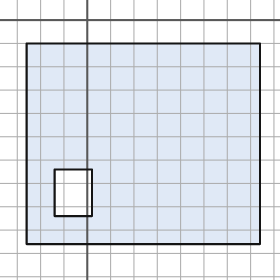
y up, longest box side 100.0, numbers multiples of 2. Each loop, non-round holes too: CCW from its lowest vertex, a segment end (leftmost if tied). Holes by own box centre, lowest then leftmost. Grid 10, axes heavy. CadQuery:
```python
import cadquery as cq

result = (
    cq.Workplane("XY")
    .moveTo(-26.0, -96.0)
    .lineTo(74.0, -96.0)
    .lineTo(74.0, -10.0)
    .lineTo(-26.0, -10.0)
    .close()
    .moveTo(-14.0, -84.0)
    .lineTo(2.0, -84.0)
    .lineTo(2.0, -64.0)
    .lineTo(-14.0, -64.0)
    .close()
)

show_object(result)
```